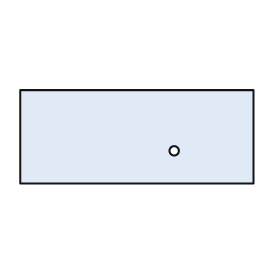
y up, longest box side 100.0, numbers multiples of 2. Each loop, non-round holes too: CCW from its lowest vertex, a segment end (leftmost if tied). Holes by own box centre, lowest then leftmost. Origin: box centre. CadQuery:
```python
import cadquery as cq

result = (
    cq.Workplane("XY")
    .moveTo(-50.0, -20.0)
    .lineTo(50.0, -20.0)
    .lineTo(50.0, 20.0)
    .lineTo(-50.0, 20.0)
    .close()
    .moveTo(16.0, -6.0)
    .circle(2.0)
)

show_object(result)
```